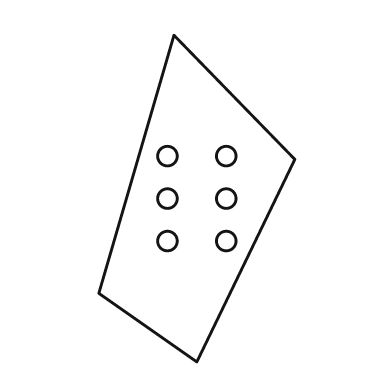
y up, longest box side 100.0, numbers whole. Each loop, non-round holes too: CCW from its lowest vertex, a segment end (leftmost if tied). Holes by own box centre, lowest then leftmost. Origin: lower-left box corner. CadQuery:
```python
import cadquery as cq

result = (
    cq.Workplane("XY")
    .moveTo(30.0, 0.0)
    .lineTo(60.0, 62.0)
    .lineTo(23.0, 100.0)
    .lineTo(0.0, 21.0)
    .close()
    .moveTo(21.0, 37.0)
    .circle(3.0)
    .moveTo(39.0, 37.0)
    .circle(3.0)
    .moveTo(21.0, 50.0)
    .circle(3.0)
    .moveTo(39.0, 50.0)
    .circle(3.0)
    .moveTo(21.0, 63.0)
    .circle(3.0)
    .moveTo(39.0, 63.0)
    .circle(3.0)
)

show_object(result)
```